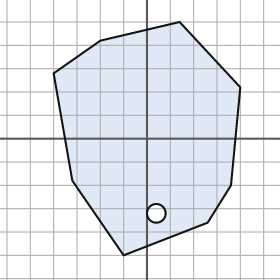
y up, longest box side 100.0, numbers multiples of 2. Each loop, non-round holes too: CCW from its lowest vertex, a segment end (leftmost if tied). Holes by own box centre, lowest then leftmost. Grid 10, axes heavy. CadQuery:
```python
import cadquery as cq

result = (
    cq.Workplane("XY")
    .moveTo(-10.0, -50.0)
    .lineTo(26.0, -36.0)
    .lineTo(36.0, -20.0)
    .lineTo(40.0, 22.0)
    .lineTo(14.0, 50.0)
    .lineTo(-20.0, 42.0)
    .lineTo(-40.0, 28.0)
    .lineTo(-32.0, -18.0)
    .close()
    .moveTo(4.0, -32.0)
    .circle(4.0)
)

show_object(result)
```